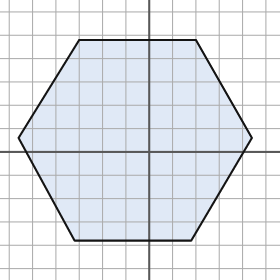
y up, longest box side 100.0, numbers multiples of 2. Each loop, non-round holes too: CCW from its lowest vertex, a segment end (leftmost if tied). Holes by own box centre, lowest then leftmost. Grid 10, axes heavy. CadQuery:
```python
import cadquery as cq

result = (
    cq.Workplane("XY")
    .moveTo(-32.0, -38.0)
    .lineTo(18.0, -38.0)
    .lineTo(44.0, 6.0)
    .lineTo(20.0, 48.0)
    .lineTo(-30.0, 48.0)
    .lineTo(-56.0, 6.0)
    .close()
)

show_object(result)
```